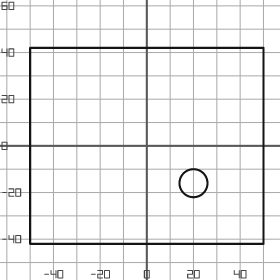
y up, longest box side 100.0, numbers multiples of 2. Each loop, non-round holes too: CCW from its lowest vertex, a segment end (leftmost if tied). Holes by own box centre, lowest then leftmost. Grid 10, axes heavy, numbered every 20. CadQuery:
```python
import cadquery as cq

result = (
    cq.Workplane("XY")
    .moveTo(-50.0, -42.0)
    .lineTo(50.0, -42.0)
    .lineTo(50.0, 42.0)
    .lineTo(-50.0, 42.0)
    .close()
    .moveTo(20.0, -16.0)
    .circle(6.0)
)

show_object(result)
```